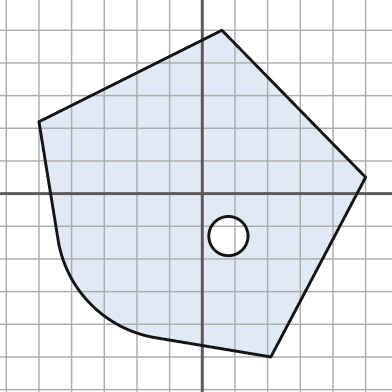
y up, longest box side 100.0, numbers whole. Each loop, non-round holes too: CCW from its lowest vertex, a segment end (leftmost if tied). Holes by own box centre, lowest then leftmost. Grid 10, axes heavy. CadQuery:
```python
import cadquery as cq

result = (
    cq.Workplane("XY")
    .moveTo(21.0, -50.0)
    .lineTo(50.0, 5.0)
    .lineTo(6.0, 50.0)
    .lineTo(-50.0, 22.0)
    .lineTo(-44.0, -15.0)
    .threePointArc((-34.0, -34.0), (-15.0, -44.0))
    .close()
    .moveTo(8.0, -13.0)
    .circle(6.0)
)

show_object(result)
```